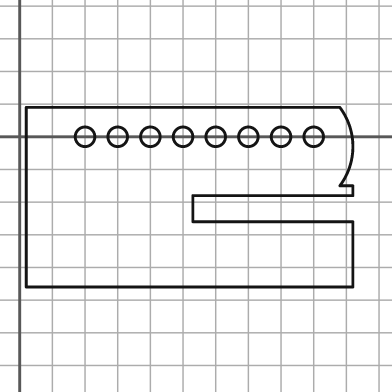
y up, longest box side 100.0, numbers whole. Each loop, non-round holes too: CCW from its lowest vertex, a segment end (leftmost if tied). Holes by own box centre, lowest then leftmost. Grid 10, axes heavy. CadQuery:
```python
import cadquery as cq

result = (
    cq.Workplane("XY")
    .moveTo(2.0, -46.0)
    .lineTo(102.0, -46.0)
    .lineTo(102.0, -26.0)
    .lineTo(53.0, -26.0)
    .lineTo(53.0, -18.0)
    .lineTo(102.0, -18.0)
    .lineTo(102.0, -15.0)
    .lineTo(98.0, -15.0)
    .threePointArc((102.0, -3.0), (98.0, 9.0))
    .lineTo(2.0, 9.0)
    .close()
    .moveTo(20.0, 0.0)
    .circle(3.0)
    .moveTo(30.0, 0.0)
    .circle(3.0)
    .moveTo(40.0, 0.0)
    .circle(3.0)
    .moveTo(50.0, 0.0)
    .circle(3.0)
    .moveTo(60.0, 0.0)
    .circle(3.0)
    .moveTo(70.0, 0.0)
    .circle(3.0)
    .moveTo(80.0, 0.0)
    .circle(3.0)
    .moveTo(90.0, 0.0)
    .circle(3.0)
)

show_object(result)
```